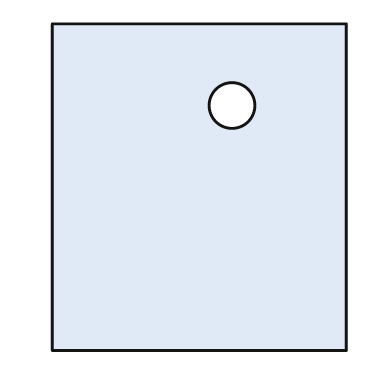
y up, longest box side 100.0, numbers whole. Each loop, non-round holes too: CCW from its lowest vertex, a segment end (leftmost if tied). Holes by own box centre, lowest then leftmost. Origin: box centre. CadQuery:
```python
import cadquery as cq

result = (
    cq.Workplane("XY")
    .moveTo(-45.0, -50.0)
    .lineTo(45.0, -50.0)
    .lineTo(45.0, 50.0)
    .lineTo(-45.0, 50.0)
    .close()
    .moveTo(10.0, 25.0)
    .circle(7.0)
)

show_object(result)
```